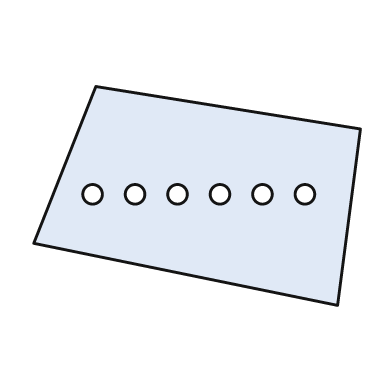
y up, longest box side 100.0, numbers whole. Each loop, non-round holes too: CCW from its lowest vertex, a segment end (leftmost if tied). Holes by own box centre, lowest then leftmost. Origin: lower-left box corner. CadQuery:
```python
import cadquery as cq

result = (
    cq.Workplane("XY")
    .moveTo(93.0, 0.0)
    .lineTo(100.0, 54.0)
    .lineTo(19.0, 67.0)
    .lineTo(0.0, 19.0)
    .close()
    .moveTo(18.0, 34.0)
    .circle(3.0)
    .moveTo(31.0, 34.0)
    .circle(3.0)
    .moveTo(44.0, 34.0)
    .circle(3.0)
    .moveTo(57.0, 34.0)
    .circle(3.0)
    .moveTo(70.0, 34.0)
    .circle(3.0)
    .moveTo(83.0, 34.0)
    .circle(3.0)
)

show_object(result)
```